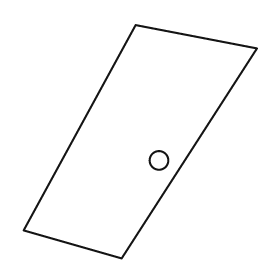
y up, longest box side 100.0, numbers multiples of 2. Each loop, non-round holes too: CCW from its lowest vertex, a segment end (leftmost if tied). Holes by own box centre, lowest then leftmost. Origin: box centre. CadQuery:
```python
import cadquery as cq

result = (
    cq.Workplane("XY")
    .moveTo(-8.0, -50.0)
    .lineTo(50.0, 40.0)
    .lineTo(-2.0, 50.0)
    .lineTo(-50.0, -38.0)
    .close()
    .moveTo(8.0, -8.0)
    .circle(4.0)
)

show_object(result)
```